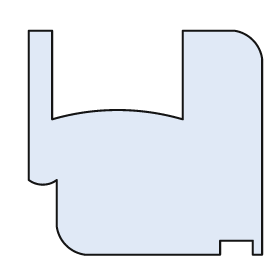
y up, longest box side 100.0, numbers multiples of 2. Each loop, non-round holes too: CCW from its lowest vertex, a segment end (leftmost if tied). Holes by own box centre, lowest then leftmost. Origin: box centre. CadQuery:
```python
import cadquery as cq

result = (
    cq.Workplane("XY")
    .moveTo(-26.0, -48.0)
    .lineTo(32.0, -48.0)
    .lineTo(32.0, -42.0)
    .lineTo(46.0, -42.0)
    .lineTo(46.0, -48.0)
    .lineTo(50.0, -48.0)
    .lineTo(50.0, 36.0)
    .threePointArc((46.0, 44.0), (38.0, 48.0))
    .lineTo(16.0, 48.0)
    .lineTo(16.0, 10.0)
    .threePointArc((-12.0, 14.0), (-40.0, 10.0))
    .lineTo(-40.0, 48.0)
    .lineTo(-50.0, 48.0)
    .lineTo(-50.0, -16.0)
    .threePointArc((-44.0, -18.0), (-38.0, -16.0))
    .lineTo(-38.0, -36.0)
    .threePointArc((-34.0, -44.0), (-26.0, -48.0))
    .close()
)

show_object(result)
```